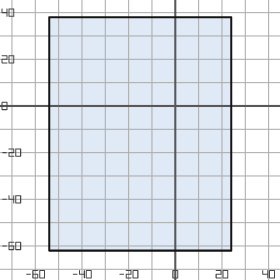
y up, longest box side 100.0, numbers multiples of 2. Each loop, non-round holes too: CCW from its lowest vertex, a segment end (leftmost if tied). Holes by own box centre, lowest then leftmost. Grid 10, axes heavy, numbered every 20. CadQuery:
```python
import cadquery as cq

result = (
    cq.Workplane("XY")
    .moveTo(-54.0, -62.0)
    .lineTo(24.0, -62.0)
    .lineTo(24.0, 38.0)
    .lineTo(-54.0, 38.0)
    .close()
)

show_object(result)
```